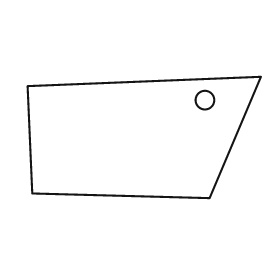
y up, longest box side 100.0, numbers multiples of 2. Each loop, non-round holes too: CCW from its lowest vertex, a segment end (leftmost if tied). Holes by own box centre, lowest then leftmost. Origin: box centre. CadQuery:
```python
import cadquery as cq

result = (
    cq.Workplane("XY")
    .moveTo(28.0, -26.0)
    .lineTo(50.0, 26.0)
    .lineTo(-50.0, 22.0)
    .lineTo(-48.0, -24.0)
    .close()
    .moveTo(26.0, 16.0)
    .circle(4.0)
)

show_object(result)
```